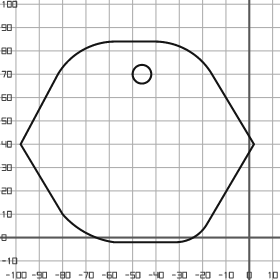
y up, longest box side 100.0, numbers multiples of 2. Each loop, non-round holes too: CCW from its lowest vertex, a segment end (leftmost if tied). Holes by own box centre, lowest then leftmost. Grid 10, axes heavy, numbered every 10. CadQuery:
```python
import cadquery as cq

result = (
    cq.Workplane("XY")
    .moveTo(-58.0, -2.0)
    .lineTo(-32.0, -2.0)
    .threePointArc((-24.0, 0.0), (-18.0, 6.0))
    .lineTo(2.0, 40.0)
    .lineTo(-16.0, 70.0)
    .threePointArc((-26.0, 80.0), (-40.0, 84.0))
    .lineTo(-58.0, 84.0)
    .threePointArc((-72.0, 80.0), (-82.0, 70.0))
    .lineTo(-98.0, 40.0)
    .lineTo(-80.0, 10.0)
    .threePointArc((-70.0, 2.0), (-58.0, -2.0))
    .close()
    .moveTo(-46.0, 70.0)
    .circle(4.0)
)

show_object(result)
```